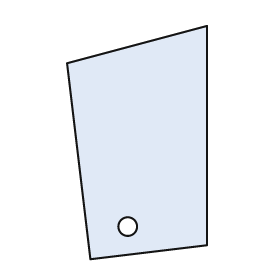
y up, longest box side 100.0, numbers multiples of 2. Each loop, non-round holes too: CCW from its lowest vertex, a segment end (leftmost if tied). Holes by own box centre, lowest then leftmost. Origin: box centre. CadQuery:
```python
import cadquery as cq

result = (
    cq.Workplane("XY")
    .moveTo(-20.0, -50.0)
    .lineTo(30.0, -44.0)
    .lineTo(30.0, 50.0)
    .lineTo(-30.0, 34.0)
    .close()
    .moveTo(-4.0, -36.0)
    .circle(4.0)
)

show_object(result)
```